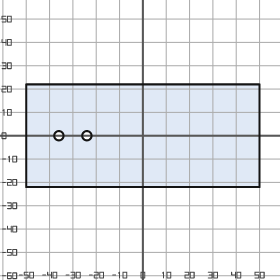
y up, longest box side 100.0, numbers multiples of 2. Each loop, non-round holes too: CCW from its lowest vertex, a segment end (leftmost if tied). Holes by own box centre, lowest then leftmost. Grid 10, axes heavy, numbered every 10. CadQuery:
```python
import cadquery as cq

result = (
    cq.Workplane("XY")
    .moveTo(-50.0, -22.0)
    .lineTo(50.0, -22.0)
    .lineTo(50.0, 22.0)
    .lineTo(-50.0, 22.0)
    .close()
    .moveTo(-36.0, 0.0)
    .circle(2.0)
    .moveTo(-24.0, 0.0)
    .circle(2.0)
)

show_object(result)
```